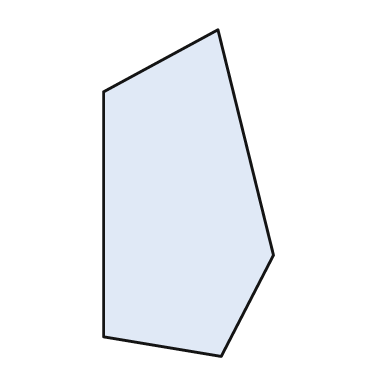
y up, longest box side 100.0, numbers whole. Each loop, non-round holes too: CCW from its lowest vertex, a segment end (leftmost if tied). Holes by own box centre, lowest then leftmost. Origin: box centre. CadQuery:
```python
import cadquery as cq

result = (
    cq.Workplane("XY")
    .moveTo(10.0, -50.0)
    .lineTo(26.0, -19.0)
    .lineTo(9.0, 50.0)
    .lineTo(-26.0, 31.0)
    .lineTo(-26.0, -44.0)
    .close()
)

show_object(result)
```